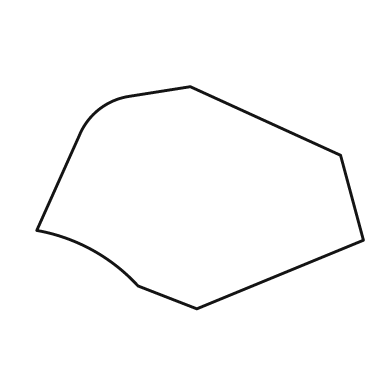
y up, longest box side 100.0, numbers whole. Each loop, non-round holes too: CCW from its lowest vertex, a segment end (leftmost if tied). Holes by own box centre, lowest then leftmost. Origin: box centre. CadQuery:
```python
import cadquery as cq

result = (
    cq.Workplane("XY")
    .moveTo(-1.0, -34.0)
    .lineTo(50.0, -13.0)
    .lineTo(43.0, 13.0)
    .lineTo(-3.0, 34.0)
    .lineTo(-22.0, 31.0)
    .threePointArc((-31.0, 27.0), (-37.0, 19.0))
    .lineTo(-50.0, -10.0)
    .threePointArc((-33.0, -16.0), (-19.0, -27.0))
    .close()
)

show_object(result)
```